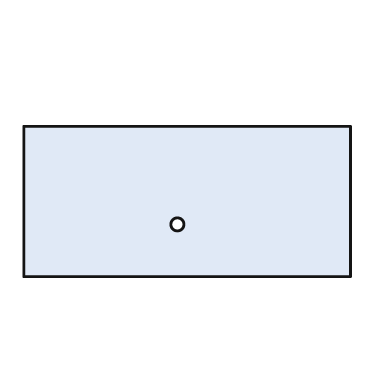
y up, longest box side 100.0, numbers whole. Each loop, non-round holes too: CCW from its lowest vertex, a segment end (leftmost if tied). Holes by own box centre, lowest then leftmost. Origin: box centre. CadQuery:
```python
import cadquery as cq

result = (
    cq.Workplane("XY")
    .moveTo(-50.0, -23.0)
    .lineTo(50.0, -23.0)
    .lineTo(50.0, 23.0)
    .lineTo(-50.0, 23.0)
    .close()
    .moveTo(-3.0, -7.0)
    .circle(2.0)
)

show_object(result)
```